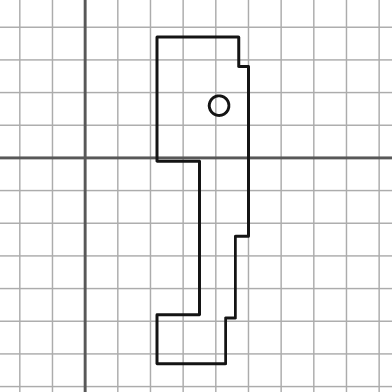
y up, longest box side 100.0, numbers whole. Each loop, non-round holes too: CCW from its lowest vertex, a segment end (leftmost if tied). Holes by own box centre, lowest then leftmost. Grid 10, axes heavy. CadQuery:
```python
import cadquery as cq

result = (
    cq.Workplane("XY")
    .moveTo(22.0, -63.0)
    .lineTo(43.0, -63.0)
    .lineTo(43.0, -49.0)
    .lineTo(46.0, -49.0)
    .lineTo(46.0, -24.0)
    .lineTo(50.0, -24.0)
    .lineTo(50.0, 28.0)
    .lineTo(47.0, 28.0)
    .lineTo(47.0, 37.0)
    .lineTo(22.0, 37.0)
    .lineTo(22.0, -1.0)
    .lineTo(35.0, -1.0)
    .lineTo(35.0, -48.0)
    .lineTo(22.0, -48.0)
    .close()
    .moveTo(41.0, 16.0)
    .circle(3.0)
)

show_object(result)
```